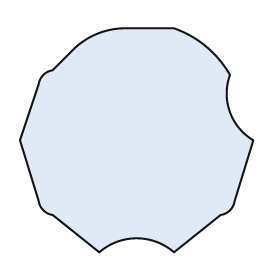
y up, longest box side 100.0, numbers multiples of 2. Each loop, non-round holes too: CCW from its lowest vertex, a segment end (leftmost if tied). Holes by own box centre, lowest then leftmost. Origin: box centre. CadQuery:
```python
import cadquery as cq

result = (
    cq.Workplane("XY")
    .moveTo(-16.0, -48.0)
    .threePointArc((0.0, -42.0), (16.0, -48.0))
    .lineTo(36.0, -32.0)
    .threePointArc((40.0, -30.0), (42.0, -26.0))
    .lineTo(50.0, 0.0)
    .threePointArc((40.0, 12.0), (40.0, 28.0))
    .threePointArc((30.0, 40.0), (16.0, 48.0))
    .lineTo(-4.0, 48.0)
    .threePointArc((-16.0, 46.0), (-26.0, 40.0))
    .lineTo(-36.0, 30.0)
    .threePointArc((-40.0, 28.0), (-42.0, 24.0))
    .lineTo(-50.0, 0.0)
    .lineTo(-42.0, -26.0)
    .threePointArc((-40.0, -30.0), (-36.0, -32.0))
    .close()
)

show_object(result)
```